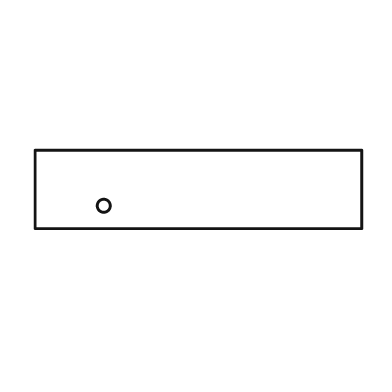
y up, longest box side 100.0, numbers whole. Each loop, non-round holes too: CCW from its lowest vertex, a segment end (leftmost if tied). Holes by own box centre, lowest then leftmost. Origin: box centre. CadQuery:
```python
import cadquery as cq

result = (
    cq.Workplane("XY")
    .moveTo(-50.0, -12.0)
    .lineTo(50.0, -12.0)
    .lineTo(50.0, 12.0)
    .lineTo(-50.0, 12.0)
    .close()
    .moveTo(-29.0, -5.0)
    .circle(2.0)
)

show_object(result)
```